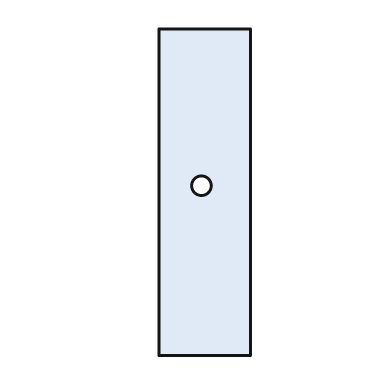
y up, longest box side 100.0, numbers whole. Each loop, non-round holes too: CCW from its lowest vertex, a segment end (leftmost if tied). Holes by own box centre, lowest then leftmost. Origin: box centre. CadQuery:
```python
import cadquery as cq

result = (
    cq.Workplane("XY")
    .moveTo(-14.0, -50.0)
    .lineTo(14.0, -50.0)
    .lineTo(14.0, 50.0)
    .lineTo(-14.0, 50.0)
    .close()
    .moveTo(-1.0, 2.0)
    .circle(3.0)
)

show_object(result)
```